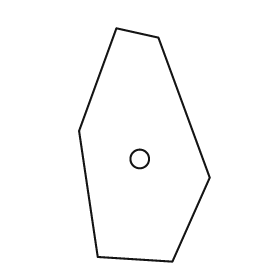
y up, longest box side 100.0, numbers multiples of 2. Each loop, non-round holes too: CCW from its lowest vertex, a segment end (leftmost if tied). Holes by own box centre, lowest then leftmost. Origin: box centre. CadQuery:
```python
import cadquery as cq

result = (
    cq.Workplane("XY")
    .moveTo(12.0, -50.0)
    .lineTo(28.0, -14.0)
    .lineTo(6.0, 46.0)
    .lineTo(-12.0, 50.0)
    .lineTo(-28.0, 6.0)
    .lineTo(-20.0, -48.0)
    .close()
    .moveTo(-2.0, -6.0)
    .circle(4.0)
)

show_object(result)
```